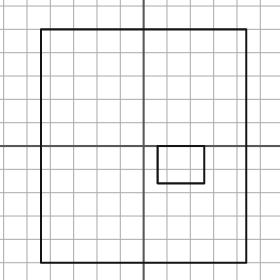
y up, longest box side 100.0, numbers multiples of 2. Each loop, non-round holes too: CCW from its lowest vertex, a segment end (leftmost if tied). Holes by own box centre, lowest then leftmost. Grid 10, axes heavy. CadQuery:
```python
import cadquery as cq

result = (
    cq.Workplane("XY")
    .moveTo(-44.0, -50.0)
    .lineTo(44.0, -50.0)
    .lineTo(44.0, 50.0)
    .lineTo(-44.0, 50.0)
    .close()
    .moveTo(6.0, -16.0)
    .lineTo(26.0, -16.0)
    .lineTo(26.0, 0.0)
    .lineTo(6.0, 0.0)
    .close()
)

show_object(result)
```